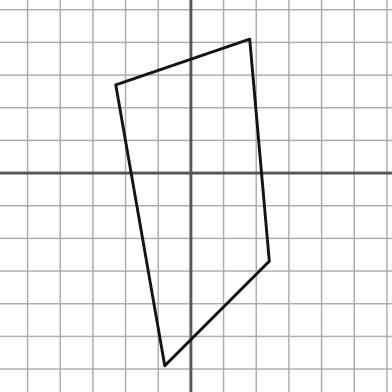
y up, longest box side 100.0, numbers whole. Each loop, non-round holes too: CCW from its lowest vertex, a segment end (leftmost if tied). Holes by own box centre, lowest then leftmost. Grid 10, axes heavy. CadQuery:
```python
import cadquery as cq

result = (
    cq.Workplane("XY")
    .moveTo(-8.0, -59.0)
    .lineTo(24.0, -27.0)
    .lineTo(18.0, 41.0)
    .lineTo(-23.0, 27.0)
    .close()
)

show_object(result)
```